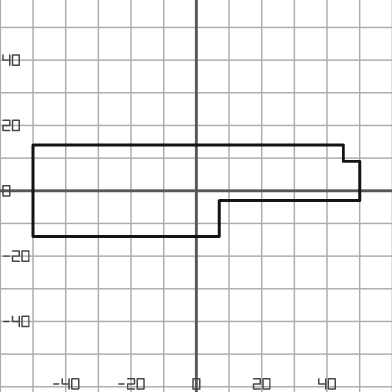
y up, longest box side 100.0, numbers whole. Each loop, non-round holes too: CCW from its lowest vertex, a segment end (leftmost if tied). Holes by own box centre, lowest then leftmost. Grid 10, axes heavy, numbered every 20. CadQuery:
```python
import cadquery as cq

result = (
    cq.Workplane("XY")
    .moveTo(-50.0, -14.0)
    .lineTo(7.0, -14.0)
    .lineTo(7.0, -3.0)
    .lineTo(50.0, -3.0)
    .lineTo(50.0, 9.0)
    .lineTo(45.0, 9.0)
    .lineTo(45.0, 14.0)
    .lineTo(-50.0, 14.0)
    .close()
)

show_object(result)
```